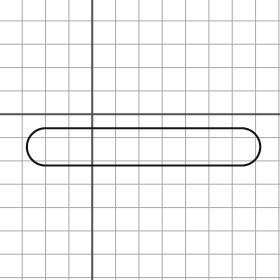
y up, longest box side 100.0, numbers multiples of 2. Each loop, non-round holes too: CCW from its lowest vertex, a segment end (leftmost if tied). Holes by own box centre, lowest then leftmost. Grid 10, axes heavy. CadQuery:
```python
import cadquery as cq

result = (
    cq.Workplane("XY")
    .moveTo(-20.0, -22.0)
    .lineTo(64.0, -22.0)
    .threePointArc((72.0, -14.0), (64.0, -6.0))
    .lineTo(-20.0, -6.0)
    .threePointArc((-28.0, -14.0), (-20.0, -22.0))
    .close()
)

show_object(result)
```